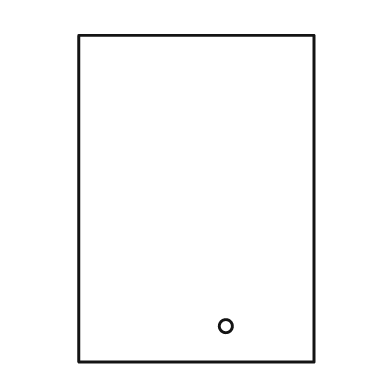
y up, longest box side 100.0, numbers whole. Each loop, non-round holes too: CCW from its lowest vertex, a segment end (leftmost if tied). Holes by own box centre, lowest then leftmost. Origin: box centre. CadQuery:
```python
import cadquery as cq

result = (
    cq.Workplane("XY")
    .moveTo(-36.0, -50.0)
    .lineTo(36.0, -50.0)
    .lineTo(36.0, 50.0)
    .lineTo(-36.0, 50.0)
    .close()
    .moveTo(9.0, -39.0)
    .circle(2.0)
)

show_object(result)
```